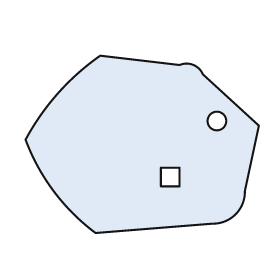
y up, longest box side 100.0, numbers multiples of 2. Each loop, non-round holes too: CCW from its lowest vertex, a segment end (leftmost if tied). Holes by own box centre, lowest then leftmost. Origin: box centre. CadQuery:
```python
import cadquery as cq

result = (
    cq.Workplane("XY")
    .moveTo(-20.0, -38.0)
    .lineTo(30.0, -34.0)
    .threePointArc((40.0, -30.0), (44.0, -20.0))
    .lineTo(50.0, 8.0)
    .lineTo(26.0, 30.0)
    .threePointArc((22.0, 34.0), (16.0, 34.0))
    .lineTo(-18.0, 38.0)
    .threePointArc((-36.0, 22.0), (-50.0, 2.0))
    .threePointArc((-38.0, -20.0), (-20.0, -38.0))
    .close()
    .moveTo(8.0, -18.0)
    .lineTo(16.0, -18.0)
    .lineTo(16.0, -10.0)
    .lineTo(8.0, -10.0)
    .close()
    .moveTo(32.0, 10.0)
    .circle(4.0)
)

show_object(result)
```